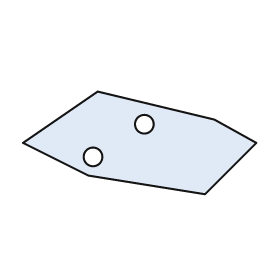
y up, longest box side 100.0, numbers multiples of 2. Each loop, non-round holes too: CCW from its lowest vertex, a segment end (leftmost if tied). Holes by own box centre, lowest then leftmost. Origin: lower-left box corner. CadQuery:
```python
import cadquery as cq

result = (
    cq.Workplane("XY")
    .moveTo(78.0, 0.0)
    .lineTo(100.0, 22.0)
    .lineTo(82.0, 32.0)
    .lineTo(32.0, 44.0)
    .lineTo(0.0, 22.0)
    .lineTo(28.0, 8.0)
    .close()
    .moveTo(30.0, 16.0)
    .circle(4.0)
    .moveTo(52.0, 30.0)
    .circle(4.0)
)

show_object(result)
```